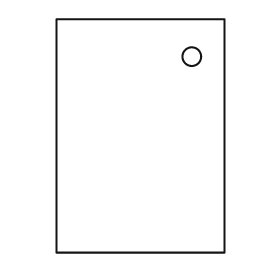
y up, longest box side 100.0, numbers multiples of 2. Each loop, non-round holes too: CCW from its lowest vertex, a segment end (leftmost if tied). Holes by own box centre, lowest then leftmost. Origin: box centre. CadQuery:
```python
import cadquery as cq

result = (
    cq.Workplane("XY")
    .moveTo(-36.0, -50.0)
    .lineTo(36.0, -50.0)
    .lineTo(36.0, 50.0)
    .lineTo(-36.0, 50.0)
    .close()
    .moveTo(22.0, 34.0)
    .circle(4.0)
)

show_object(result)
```